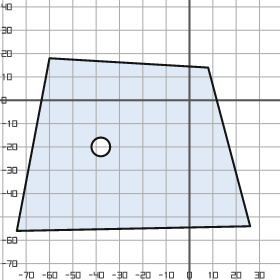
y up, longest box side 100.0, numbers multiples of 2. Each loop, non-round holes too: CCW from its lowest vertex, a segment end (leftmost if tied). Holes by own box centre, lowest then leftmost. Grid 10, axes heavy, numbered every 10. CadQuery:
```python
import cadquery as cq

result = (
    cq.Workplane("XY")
    .moveTo(-74.0, -56.0)
    .lineTo(26.0, -54.0)
    .lineTo(8.0, 14.0)
    .lineTo(-60.0, 18.0)
    .close()
    .moveTo(-38.0, -20.0)
    .circle(4.0)
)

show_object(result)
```